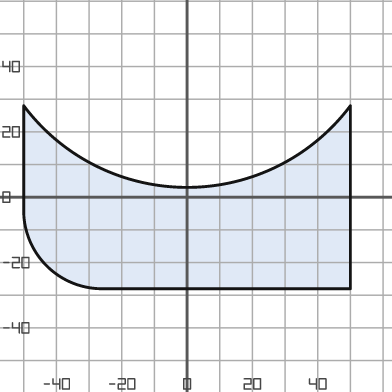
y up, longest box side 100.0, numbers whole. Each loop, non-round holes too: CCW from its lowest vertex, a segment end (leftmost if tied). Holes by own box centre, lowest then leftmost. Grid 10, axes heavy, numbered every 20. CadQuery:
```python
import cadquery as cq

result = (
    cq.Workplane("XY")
    .moveTo(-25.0, -28.0)
    .lineTo(50.0, -28.0)
    .lineTo(50.0, 28.0)
    .threePointArc((0.0, 3.0), (-50.0, 28.0))
    .lineTo(-50.0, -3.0)
    .threePointArc((-43.0, -21.0), (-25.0, -28.0))
    .close()
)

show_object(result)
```